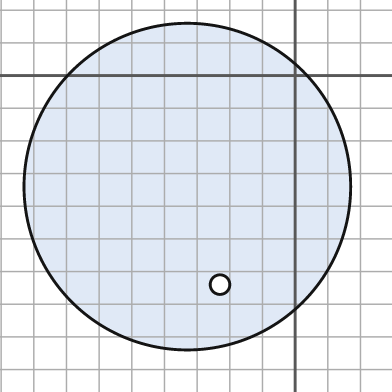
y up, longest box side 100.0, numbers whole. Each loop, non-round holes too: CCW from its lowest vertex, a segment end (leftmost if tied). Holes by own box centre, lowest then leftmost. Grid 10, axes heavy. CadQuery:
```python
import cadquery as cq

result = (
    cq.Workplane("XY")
    .moveTo(-33.0, -34.0)
    .circle(50.0)
    .moveTo(-23.0, -64.0)
    .circle(3.0)
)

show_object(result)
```